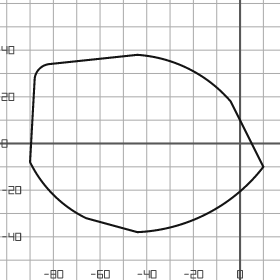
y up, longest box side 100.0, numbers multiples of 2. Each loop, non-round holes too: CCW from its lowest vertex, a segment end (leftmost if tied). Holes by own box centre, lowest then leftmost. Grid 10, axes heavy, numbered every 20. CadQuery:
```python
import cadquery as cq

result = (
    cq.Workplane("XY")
    .moveTo(-44.0, -38.0)
    .threePointArc((-14.0, -30.0), (10.0, -10.0))
    .lineTo(-4.0, 18.0)
    .threePointArc((-22.0, 32.0), (-44.0, 38.0))
    .lineTo(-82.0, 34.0)
    .threePointArc((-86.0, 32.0), (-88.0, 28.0))
    .lineTo(-90.0, -8.0)
    .threePointArc((-80.0, -22.0), (-66.0, -32.0))
    .close()
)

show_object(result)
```